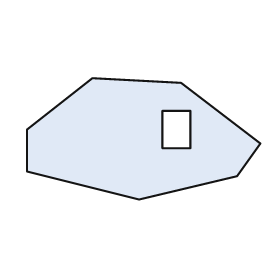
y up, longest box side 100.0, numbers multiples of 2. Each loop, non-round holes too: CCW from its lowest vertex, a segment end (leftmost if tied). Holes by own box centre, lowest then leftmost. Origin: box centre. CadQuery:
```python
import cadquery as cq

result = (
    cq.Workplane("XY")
    .moveTo(-2.0, -26.0)
    .lineTo(40.0, -16.0)
    .lineTo(50.0, -2.0)
    .lineTo(16.0, 24.0)
    .lineTo(-22.0, 26.0)
    .lineTo(-50.0, 4.0)
    .lineTo(-50.0, -14.0)
    .close()
    .moveTo(8.0, -4.0)
    .lineTo(20.0, -4.0)
    .lineTo(20.0, 12.0)
    .lineTo(8.0, 12.0)
    .close()
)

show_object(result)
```